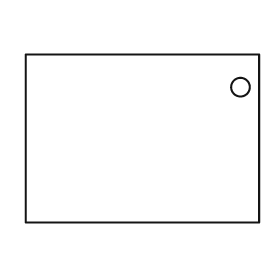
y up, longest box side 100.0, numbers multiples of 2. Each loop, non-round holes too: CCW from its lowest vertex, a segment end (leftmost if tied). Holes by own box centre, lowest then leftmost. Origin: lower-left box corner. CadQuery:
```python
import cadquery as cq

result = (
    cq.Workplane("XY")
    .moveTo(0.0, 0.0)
    .lineTo(100.0, 0.0)
    .lineTo(100.0, 72.0)
    .lineTo(0.0, 72.0)
    .close()
    .moveTo(92.0, 58.0)
    .circle(4.0)
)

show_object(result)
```